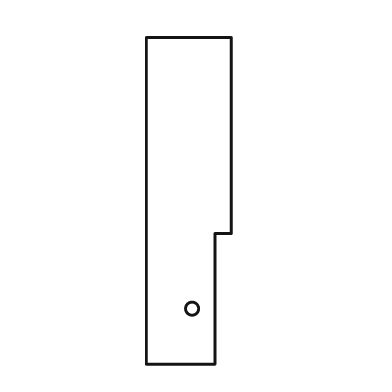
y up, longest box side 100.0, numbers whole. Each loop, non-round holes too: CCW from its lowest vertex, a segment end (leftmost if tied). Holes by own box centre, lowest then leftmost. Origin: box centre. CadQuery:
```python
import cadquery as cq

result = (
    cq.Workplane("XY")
    .moveTo(-13.0, -50.0)
    .lineTo(8.0, -50.0)
    .lineTo(8.0, -10.0)
    .lineTo(13.0, -10.0)
    .lineTo(13.0, 50.0)
    .lineTo(-13.0, 50.0)
    .close()
    .moveTo(1.0, -33.0)
    .circle(2.0)
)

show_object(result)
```